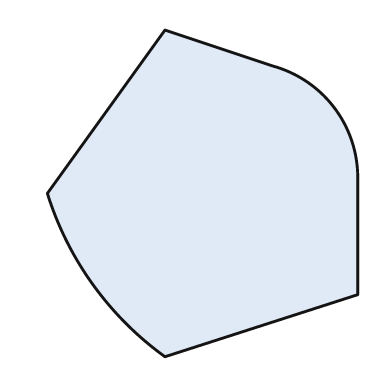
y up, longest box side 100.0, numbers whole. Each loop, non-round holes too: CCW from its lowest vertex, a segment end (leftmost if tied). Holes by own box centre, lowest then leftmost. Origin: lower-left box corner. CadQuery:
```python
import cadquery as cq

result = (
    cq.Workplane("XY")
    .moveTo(36.0, 0.0)
    .lineTo(95.0, 19.0)
    .lineTo(95.0, 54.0)
    .threePointArc((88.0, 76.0), (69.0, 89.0))
    .lineTo(36.0, 100.0)
    .lineTo(0.0, 50.0)
    .threePointArc((14.0, 22.0), (36.0, 0.0))
    .close()
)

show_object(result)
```